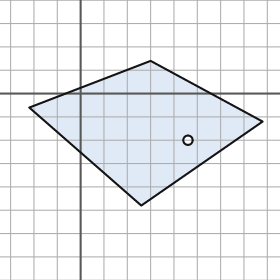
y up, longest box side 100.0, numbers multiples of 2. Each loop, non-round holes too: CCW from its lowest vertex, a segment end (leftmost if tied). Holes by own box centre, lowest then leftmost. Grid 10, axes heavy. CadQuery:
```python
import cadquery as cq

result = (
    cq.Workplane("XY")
    .moveTo(26.0, -48.0)
    .lineTo(78.0, -12.0)
    .lineTo(30.0, 14.0)
    .lineTo(-22.0, -6.0)
    .close()
    .moveTo(46.0, -20.0)
    .circle(2.0)
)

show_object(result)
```